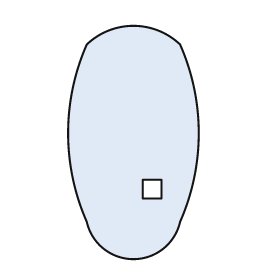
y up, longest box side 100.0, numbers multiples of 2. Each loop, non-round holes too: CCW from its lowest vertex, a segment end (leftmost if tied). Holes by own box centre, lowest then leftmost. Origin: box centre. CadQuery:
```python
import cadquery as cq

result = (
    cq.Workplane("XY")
    .moveTo(-20.0, -34.0)
    .threePointArc((0.0, -50.0), (20.0, -34.0))
    .threePointArc((28.0, 4.0), (20.0, 42.0))
    .threePointArc((0.0, 50.0), (-20.0, 42.0))
    .threePointArc((-28.0, 4.0), (-20.0, -34.0))
    .close()
    .moveTo(4.0, -24.0)
    .lineTo(12.0, -24.0)
    .lineTo(12.0, -16.0)
    .lineTo(4.0, -16.0)
    .close()
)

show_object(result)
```